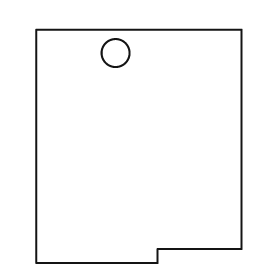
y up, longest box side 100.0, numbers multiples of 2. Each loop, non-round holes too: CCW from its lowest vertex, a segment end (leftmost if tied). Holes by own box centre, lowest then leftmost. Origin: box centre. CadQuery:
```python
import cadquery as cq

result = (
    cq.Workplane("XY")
    .moveTo(-44.0, -50.0)
    .lineTo(8.0, -50.0)
    .lineTo(8.0, -44.0)
    .lineTo(44.0, -44.0)
    .lineTo(44.0, 50.0)
    .lineTo(-44.0, 50.0)
    .close()
    .moveTo(-10.0, 40.0)
    .circle(6.0)
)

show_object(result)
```